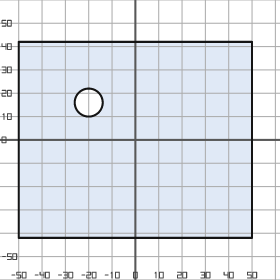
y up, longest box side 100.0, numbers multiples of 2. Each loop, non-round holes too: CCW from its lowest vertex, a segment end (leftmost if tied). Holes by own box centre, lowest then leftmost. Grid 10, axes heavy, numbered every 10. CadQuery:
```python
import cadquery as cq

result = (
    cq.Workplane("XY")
    .moveTo(-50.0, -42.0)
    .lineTo(50.0, -42.0)
    .lineTo(50.0, 42.0)
    .lineTo(-50.0, 42.0)
    .close()
    .moveTo(-20.0, 16.0)
    .circle(6.0)
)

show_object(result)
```